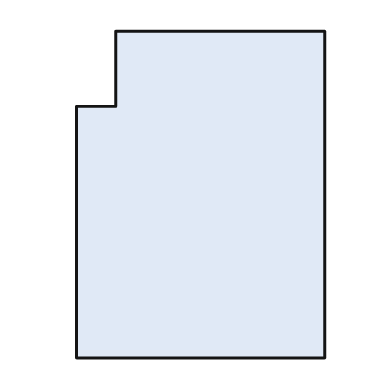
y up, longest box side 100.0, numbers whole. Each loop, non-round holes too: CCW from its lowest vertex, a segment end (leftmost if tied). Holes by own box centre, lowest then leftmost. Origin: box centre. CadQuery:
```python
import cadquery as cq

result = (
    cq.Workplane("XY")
    .moveTo(-38.0, -50.0)
    .lineTo(38.0, -50.0)
    .lineTo(38.0, 50.0)
    .lineTo(-26.0, 50.0)
    .lineTo(-26.0, 27.0)
    .lineTo(-38.0, 27.0)
    .close()
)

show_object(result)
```